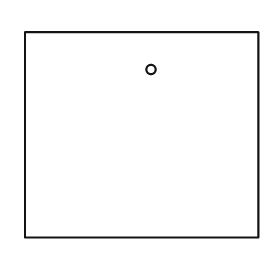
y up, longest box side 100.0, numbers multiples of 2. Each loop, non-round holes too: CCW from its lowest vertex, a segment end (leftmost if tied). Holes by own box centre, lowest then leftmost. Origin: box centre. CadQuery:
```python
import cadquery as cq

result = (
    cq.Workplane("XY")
    .moveTo(-50.0, -44.0)
    .lineTo(50.0, -44.0)
    .lineTo(50.0, 44.0)
    .lineTo(-50.0, 44.0)
    .close()
    .moveTo(4.0, 28.0)
    .circle(2.0)
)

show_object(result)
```